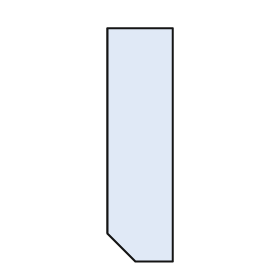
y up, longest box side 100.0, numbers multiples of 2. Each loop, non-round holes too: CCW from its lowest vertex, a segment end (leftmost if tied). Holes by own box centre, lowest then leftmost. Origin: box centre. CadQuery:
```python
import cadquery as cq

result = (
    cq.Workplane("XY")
    .moveTo(-2.0, -50.0)
    .lineTo(14.0, -50.0)
    .lineTo(14.0, 50.0)
    .lineTo(-14.0, 50.0)
    .lineTo(-14.0, -38.0)
    .close()
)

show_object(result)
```